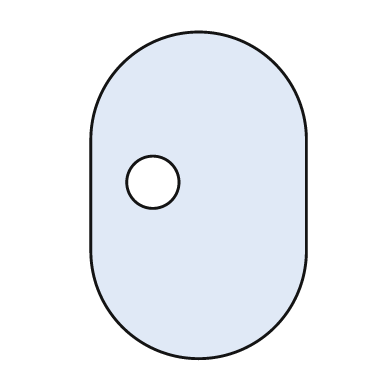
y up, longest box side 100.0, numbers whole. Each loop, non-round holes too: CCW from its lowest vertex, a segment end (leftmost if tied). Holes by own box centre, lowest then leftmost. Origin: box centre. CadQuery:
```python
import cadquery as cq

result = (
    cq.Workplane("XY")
    .moveTo(-33.0, -17.0)
    .threePointArc((0.0, -50.0), (33.0, -17.0))
    .lineTo(33.0, 17.0)
    .threePointArc((0.0, 50.0), (-33.0, 17.0))
    .close()
    .moveTo(-14.0, 4.0)
    .circle(8.0)
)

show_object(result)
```